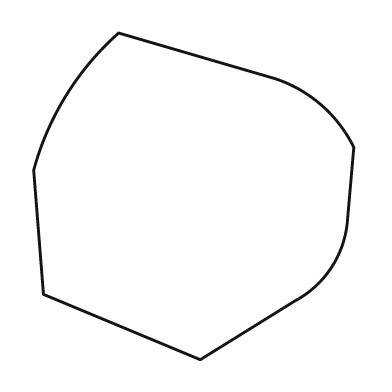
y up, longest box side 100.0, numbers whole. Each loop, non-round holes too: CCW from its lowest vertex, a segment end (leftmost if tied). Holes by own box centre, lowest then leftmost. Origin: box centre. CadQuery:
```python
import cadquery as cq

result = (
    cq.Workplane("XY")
    .moveTo(2.0, -50.0)
    .lineTo(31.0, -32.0)
    .threePointArc((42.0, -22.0), (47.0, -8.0))
    .lineTo(49.0, 15.0)
    .threePointArc((39.0, 28.0), (25.0, 36.0))
    .lineTo(-23.0, 50.0)
    .threePointArc((-39.0, 31.0), (-49.0, 8.0))
    .lineTo(-46.0, -30.0)
    .close()
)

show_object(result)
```